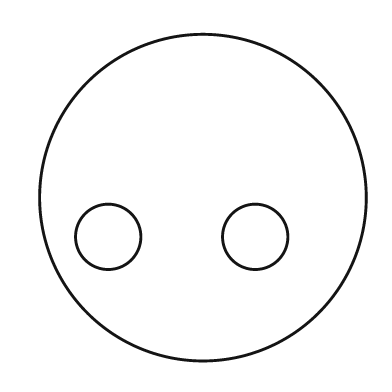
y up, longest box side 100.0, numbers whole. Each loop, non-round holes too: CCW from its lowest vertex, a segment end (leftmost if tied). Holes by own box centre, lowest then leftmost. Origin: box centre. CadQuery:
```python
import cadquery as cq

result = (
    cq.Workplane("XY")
    .moveTo(0.0, 0.0)
    .circle(50.0)
    .moveTo(-29.0, -12.0)
    .circle(10.0)
    .moveTo(16.0, -12.0)
    .circle(10.0)
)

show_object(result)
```